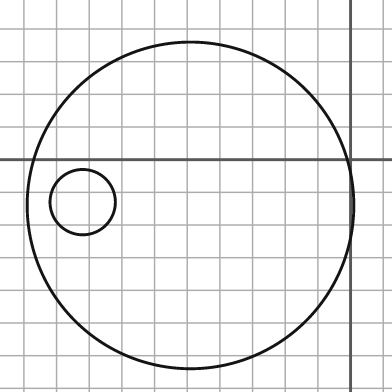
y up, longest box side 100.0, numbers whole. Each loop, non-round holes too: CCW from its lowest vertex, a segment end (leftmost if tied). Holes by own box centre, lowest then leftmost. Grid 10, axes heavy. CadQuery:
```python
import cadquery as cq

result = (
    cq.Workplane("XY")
    .moveTo(-49.0, -14.0)
    .circle(50.0)
    .moveTo(-82.0, -13.0)
    .circle(10.0)
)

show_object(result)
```